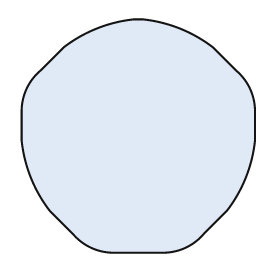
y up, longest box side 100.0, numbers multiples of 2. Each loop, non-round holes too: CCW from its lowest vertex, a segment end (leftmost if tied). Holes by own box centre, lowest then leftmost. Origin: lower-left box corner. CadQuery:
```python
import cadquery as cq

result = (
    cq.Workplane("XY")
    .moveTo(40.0, 0.0)
    .lineTo(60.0, 0.0)
    .threePointArc((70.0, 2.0), (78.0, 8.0))
    .lineTo(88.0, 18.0)
    .threePointArc((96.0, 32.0), (100.0, 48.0))
    .lineTo(100.0, 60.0)
    .threePointArc((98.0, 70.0), (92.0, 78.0))
    .lineTo(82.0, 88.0)
    .threePointArc((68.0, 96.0), (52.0, 100.0))
    .lineTo(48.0, 100.0)
    .threePointArc((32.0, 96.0), (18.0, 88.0))
    .lineTo(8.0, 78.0)
    .threePointArc((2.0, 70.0), (0.0, 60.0))
    .lineTo(0.0, 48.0)
    .threePointArc((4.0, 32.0), (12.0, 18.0))
    .lineTo(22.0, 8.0)
    .threePointArc((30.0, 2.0), (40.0, 0.0))
    .close()
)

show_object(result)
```